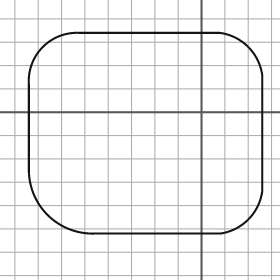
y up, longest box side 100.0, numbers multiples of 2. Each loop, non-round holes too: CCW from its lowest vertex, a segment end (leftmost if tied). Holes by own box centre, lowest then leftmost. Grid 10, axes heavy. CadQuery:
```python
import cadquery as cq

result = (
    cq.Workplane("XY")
    .moveTo(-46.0, -52.0)
    .lineTo(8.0, -52.0)
    .threePointArc((20.0, -46.0), (26.0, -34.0))
    .lineTo(26.0, 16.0)
    .threePointArc((20.0, 28.0), (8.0, 34.0))
    .lineTo(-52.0, 34.0)
    .threePointArc((-68.0, 28.0), (-74.0, 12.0))
    .lineTo(-74.0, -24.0)
    .threePointArc((-66.0, -44.0), (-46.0, -52.0))
    .close()
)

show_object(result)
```